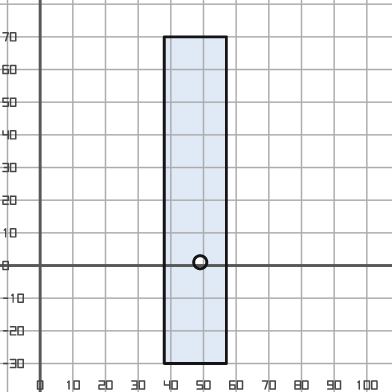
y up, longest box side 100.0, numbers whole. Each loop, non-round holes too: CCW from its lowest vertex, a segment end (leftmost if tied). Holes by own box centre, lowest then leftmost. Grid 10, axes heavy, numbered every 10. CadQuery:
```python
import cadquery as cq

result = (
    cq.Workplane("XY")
    .moveTo(38.0, -30.0)
    .lineTo(57.0, -30.0)
    .lineTo(57.0, 70.0)
    .lineTo(38.0, 70.0)
    .close()
    .moveTo(49.0, 1.0)
    .circle(2.0)
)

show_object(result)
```